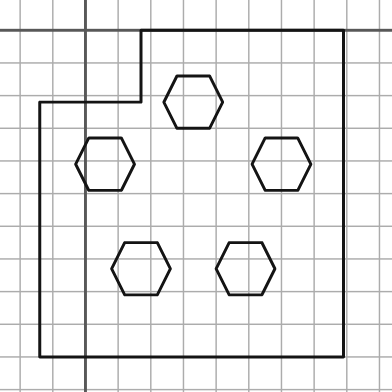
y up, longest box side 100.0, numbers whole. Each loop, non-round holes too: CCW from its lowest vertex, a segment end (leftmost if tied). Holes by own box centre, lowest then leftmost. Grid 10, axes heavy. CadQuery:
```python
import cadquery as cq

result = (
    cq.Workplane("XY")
    .moveTo(-14.0, -100.0)
    .lineTo(79.0, -100.0)
    .lineTo(79.0, 0.0)
    .lineTo(17.0, 0.0)
    .lineTo(17.0, -22.0)
    .lineTo(-14.0, -22.0)
    .close()
    .moveTo(12.0, -81.0)
    .lineTo(22.0, -81.0)
    .lineTo(26.0, -73.0)
    .lineTo(22.0, -65.0)
    .lineTo(12.0, -65.0)
    .lineTo(8.0, -73.0)
    .close()
    .moveTo(44.0, -81.0)
    .lineTo(54.0, -81.0)
    .lineTo(58.0, -73.0)
    .lineTo(54.0, -65.0)
    .lineTo(44.0, -65.0)
    .lineTo(40.0, -73.0)
    .close()
    .moveTo(1.0, -49.0)
    .lineTo(11.0, -49.0)
    .lineTo(15.0, -41.0)
    .lineTo(11.0, -33.0)
    .lineTo(1.0, -33.0)
    .lineTo(-3.0, -41.0)
    .close()
    .moveTo(55.0, -49.0)
    .lineTo(65.0, -49.0)
    .lineTo(69.0, -41.0)
    .lineTo(65.0, -33.0)
    .lineTo(55.0, -33.0)
    .lineTo(51.0, -41.0)
    .close()
    .moveTo(28.0, -30.0)
    .lineTo(38.0, -30.0)
    .lineTo(42.0, -22.0)
    .lineTo(38.0, -14.0)
    .lineTo(28.0, -14.0)
    .lineTo(24.0, -22.0)
    .close()
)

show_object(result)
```